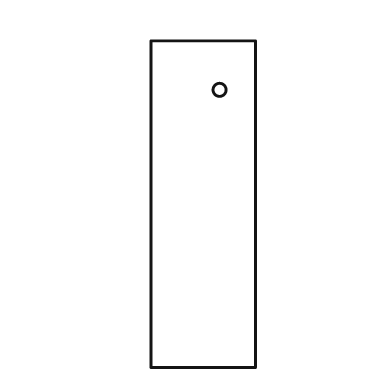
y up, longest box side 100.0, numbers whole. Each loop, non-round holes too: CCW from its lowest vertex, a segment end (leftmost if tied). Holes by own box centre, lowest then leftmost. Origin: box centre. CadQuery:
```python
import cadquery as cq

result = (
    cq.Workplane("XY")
    .moveTo(-16.0, -50.0)
    .lineTo(16.0, -50.0)
    .lineTo(16.0, 50.0)
    .lineTo(-16.0, 50.0)
    .close()
    .moveTo(5.0, 35.0)
    .circle(2.0)
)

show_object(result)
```